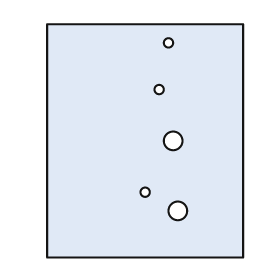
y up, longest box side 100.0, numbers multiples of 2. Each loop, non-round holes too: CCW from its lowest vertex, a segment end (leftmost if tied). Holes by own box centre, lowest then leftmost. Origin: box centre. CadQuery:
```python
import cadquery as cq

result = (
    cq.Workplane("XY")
    .moveTo(-42.0, -50.0)
    .lineTo(42.0, -50.0)
    .lineTo(42.0, 50.0)
    .lineTo(-42.0, 50.0)
    .close()
    .moveTo(14.0, -30.0)
    .circle(4.0)
    .moveTo(0.0, -22.0)
    .circle(2.0)
    .moveTo(12.0, 0.0)
    .circle(4.0)
    .moveTo(6.0, 22.0)
    .circle(2.0)
    .moveTo(10.0, 42.0)
    .circle(2.0)
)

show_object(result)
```